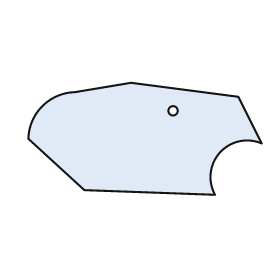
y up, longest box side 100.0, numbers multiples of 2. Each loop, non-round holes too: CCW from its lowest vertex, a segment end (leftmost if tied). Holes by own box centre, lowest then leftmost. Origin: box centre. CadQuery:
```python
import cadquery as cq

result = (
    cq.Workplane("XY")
    .moveTo(30.0, -24.0)
    .threePointArc((32.0, -6.0), (50.0, -2.0))
    .lineTo(40.0, 18.0)
    .lineTo(-6.0, 24.0)
    .lineTo(-30.0, 20.0)
    .threePointArc((-44.0, 14.0), (-50.0, 0.0))
    .lineTo(-26.0, -22.0)
    .close()
    .moveTo(12.0, 12.0)
    .circle(2.0)
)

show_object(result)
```